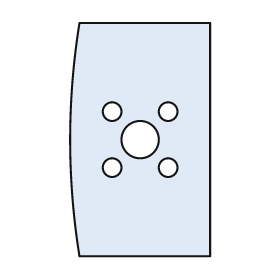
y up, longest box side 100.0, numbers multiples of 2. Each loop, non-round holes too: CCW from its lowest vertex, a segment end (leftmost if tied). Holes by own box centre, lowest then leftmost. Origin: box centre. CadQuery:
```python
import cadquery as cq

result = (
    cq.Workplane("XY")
    .moveTo(-26.0, -50.0)
    .lineTo(30.0, -50.0)
    .lineTo(30.0, 50.0)
    .lineTo(-26.0, 50.0)
    .threePointArc((-30.0, 0.0), (-26.0, -50.0))
    .close()
    .moveTo(-12.0, -12.0)
    .circle(4.0)
    .moveTo(12.0, -12.0)
    .circle(4.0)
    .moveTo(0.0, 0.0)
    .circle(8.0)
    .moveTo(-12.0, 12.0)
    .circle(4.0)
    .moveTo(12.0, 12.0)
    .circle(4.0)
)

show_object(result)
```